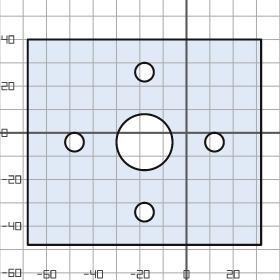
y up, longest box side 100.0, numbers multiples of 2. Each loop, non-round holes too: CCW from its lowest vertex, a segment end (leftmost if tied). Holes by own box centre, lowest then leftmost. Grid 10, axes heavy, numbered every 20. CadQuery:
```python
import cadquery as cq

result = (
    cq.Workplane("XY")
    .moveTo(-68.0, -48.0)
    .lineTo(32.0, -48.0)
    .lineTo(32.0, 40.0)
    .lineTo(-68.0, 40.0)
    .close()
    .moveTo(-18.0, -34.0)
    .circle(4.0)
    .moveTo(-48.0, -4.0)
    .circle(4.0)
    .moveTo(-18.0, -4.0)
    .circle(12.0)
    .moveTo(12.0, -4.0)
    .circle(4.0)
    .moveTo(-18.0, 26.0)
    .circle(4.0)
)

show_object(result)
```